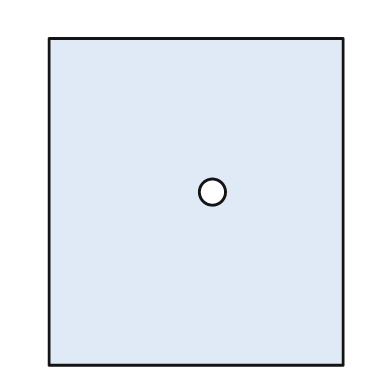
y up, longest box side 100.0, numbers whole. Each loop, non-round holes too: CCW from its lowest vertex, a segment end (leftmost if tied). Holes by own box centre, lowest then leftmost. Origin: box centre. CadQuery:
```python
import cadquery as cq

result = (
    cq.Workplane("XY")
    .moveTo(-45.0, -50.0)
    .lineTo(45.0, -50.0)
    .lineTo(45.0, 50.0)
    .lineTo(-45.0, 50.0)
    .close()
    .moveTo(5.0, 3.0)
    .circle(4.0)
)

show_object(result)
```